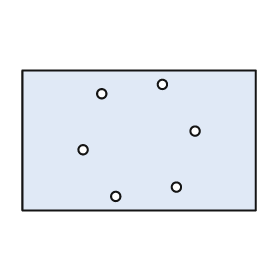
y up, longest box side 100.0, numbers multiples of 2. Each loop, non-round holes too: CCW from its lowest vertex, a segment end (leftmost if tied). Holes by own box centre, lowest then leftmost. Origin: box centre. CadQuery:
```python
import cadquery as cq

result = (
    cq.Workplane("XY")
    .moveTo(-50.0, -30.0)
    .lineTo(50.0, -30.0)
    .lineTo(50.0, 30.0)
    .lineTo(-50.0, 30.0)
    .close()
    .moveTo(-10.0, -24.0)
    .circle(2.0)
    .moveTo(16.0, -20.0)
    .circle(2.0)
    .moveTo(-24.0, -4.0)
    .circle(2.0)
    .moveTo(24.0, 4.0)
    .circle(2.0)
    .moveTo(-16.0, 20.0)
    .circle(2.0)
    .moveTo(10.0, 24.0)
    .circle(2.0)
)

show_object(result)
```